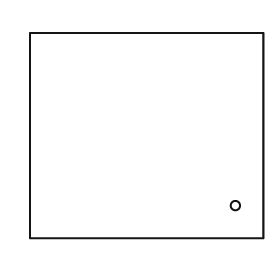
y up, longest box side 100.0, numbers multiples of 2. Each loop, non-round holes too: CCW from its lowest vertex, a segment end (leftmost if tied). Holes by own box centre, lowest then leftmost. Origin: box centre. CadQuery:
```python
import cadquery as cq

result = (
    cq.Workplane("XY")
    .moveTo(-50.0, -44.0)
    .lineTo(50.0, -44.0)
    .lineTo(50.0, 44.0)
    .lineTo(-50.0, 44.0)
    .close()
    .moveTo(38.0, -30.0)
    .circle(2.0)
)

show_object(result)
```